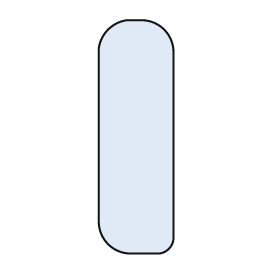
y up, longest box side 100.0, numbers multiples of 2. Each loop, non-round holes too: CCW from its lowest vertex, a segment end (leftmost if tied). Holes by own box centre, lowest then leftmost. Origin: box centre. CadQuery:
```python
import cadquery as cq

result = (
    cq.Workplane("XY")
    .moveTo(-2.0, -50.0)
    .lineTo(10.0, -50.0)
    .threePointArc((14.0, -48.0), (16.0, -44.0))
    .lineTo(16.0, 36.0)
    .threePointArc((12.0, 46.0), (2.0, 50.0))
    .lineTo(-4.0, 50.0)
    .threePointArc((-12.0, 46.0), (-16.0, 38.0))
    .lineTo(-16.0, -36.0)
    .threePointArc((-12.0, -46.0), (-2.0, -50.0))
    .close()
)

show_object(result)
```